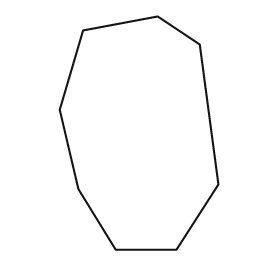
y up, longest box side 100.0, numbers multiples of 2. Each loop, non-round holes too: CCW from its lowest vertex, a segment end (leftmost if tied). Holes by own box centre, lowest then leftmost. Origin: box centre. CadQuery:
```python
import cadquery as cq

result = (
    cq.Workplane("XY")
    .moveTo(-10.0, -50.0)
    .lineTo(16.0, -50.0)
    .lineTo(34.0, -22.0)
    .lineTo(26.0, 38.0)
    .lineTo(8.0, 50.0)
    .lineTo(-24.0, 44.0)
    .lineTo(-34.0, 10.0)
    .lineTo(-26.0, -24.0)
    .close()
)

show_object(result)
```